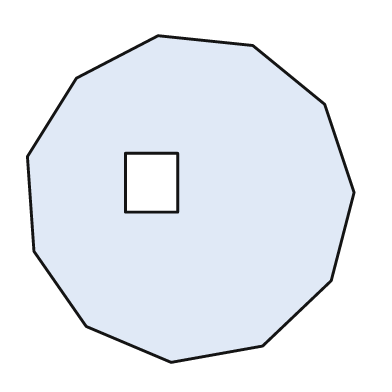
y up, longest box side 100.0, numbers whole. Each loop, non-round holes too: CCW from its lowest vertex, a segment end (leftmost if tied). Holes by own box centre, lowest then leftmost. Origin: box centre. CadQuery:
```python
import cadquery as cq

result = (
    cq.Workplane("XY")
    .moveTo(-6.0, -50.0)
    .lineTo(22.0, -45.0)
    .lineTo(43.0, -25.0)
    .lineTo(50.0, 2.0)
    .lineTo(41.0, 29.0)
    .lineTo(19.0, 47.0)
    .lineTo(-10.0, 50.0)
    .lineTo(-35.0, 37.0)
    .lineTo(-50.0, 13.0)
    .lineTo(-48.0, -16.0)
    .lineTo(-32.0, -39.0)
    .close()
    .moveTo(-20.0, -4.0)
    .lineTo(-4.0, -4.0)
    .lineTo(-4.0, 14.0)
    .lineTo(-20.0, 14.0)
    .close()
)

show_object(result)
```